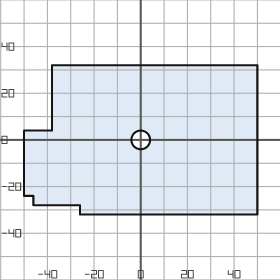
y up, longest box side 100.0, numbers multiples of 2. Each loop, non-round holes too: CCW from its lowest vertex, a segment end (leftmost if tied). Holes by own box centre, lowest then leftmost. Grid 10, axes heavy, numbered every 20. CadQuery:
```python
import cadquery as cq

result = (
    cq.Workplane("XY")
    .moveTo(-26.0, -32.0)
    .lineTo(50.0, -32.0)
    .lineTo(50.0, 32.0)
    .lineTo(-38.0, 32.0)
    .lineTo(-38.0, 4.0)
    .lineTo(-50.0, 4.0)
    .lineTo(-50.0, -24.0)
    .lineTo(-46.0, -24.0)
    .lineTo(-46.0, -28.0)
    .lineTo(-26.0, -28.0)
    .close()
    .moveTo(0.0, 0.0)
    .circle(4.0)
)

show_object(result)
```